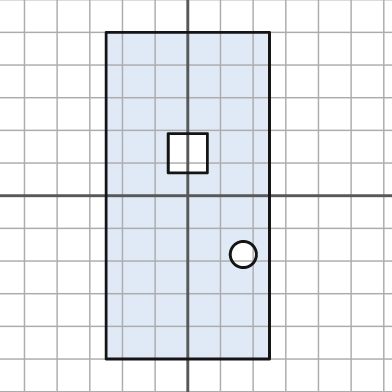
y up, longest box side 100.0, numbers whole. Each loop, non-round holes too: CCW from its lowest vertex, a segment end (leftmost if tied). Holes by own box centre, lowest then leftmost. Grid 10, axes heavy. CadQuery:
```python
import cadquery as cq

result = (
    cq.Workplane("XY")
    .moveTo(-25.0, -50.0)
    .lineTo(25.0, -50.0)
    .lineTo(25.0, 50.0)
    .lineTo(-25.0, 50.0)
    .close()
    .moveTo(17.0, -18.0)
    .circle(4.0)
    .moveTo(-6.0, 7.0)
    .lineTo(6.0, 7.0)
    .lineTo(6.0, 19.0)
    .lineTo(-6.0, 19.0)
    .close()
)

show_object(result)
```